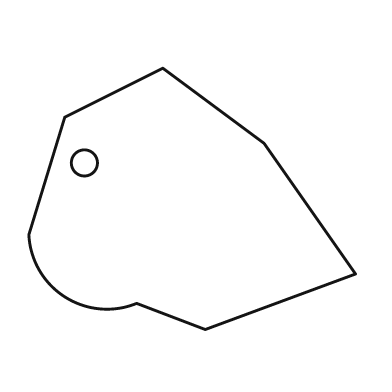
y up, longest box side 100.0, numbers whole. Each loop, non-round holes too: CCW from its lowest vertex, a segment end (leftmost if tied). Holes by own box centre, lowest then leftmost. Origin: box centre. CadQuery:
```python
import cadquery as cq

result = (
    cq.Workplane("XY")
    .moveTo(4.0, -40.0)
    .lineTo(50.0, -23.0)
    .lineTo(22.0, 17.0)
    .lineTo(-9.0, 40.0)
    .lineTo(-39.0, 25.0)
    .lineTo(-50.0, -11.0)
    .threePointArc((-39.0, -30.0), (-17.0, -32.0))
    .close()
    .moveTo(-33.0, 11.0)
    .circle(4.0)
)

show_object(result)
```